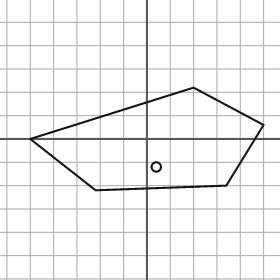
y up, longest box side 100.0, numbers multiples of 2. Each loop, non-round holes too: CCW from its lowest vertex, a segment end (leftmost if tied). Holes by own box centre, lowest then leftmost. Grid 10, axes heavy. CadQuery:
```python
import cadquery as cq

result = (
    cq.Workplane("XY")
    .moveTo(-22.0, -22.0)
    .lineTo(34.0, -20.0)
    .lineTo(50.0, 6.0)
    .lineTo(20.0, 22.0)
    .lineTo(-50.0, 0.0)
    .close()
    .moveTo(4.0, -12.0)
    .circle(2.0)
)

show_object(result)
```